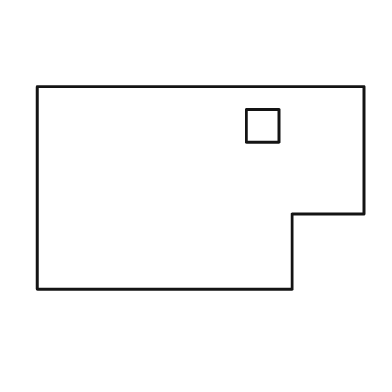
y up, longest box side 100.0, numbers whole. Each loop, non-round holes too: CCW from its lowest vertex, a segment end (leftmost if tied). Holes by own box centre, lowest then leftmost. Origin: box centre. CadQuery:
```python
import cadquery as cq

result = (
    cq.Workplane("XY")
    .moveTo(-50.0, -31.0)
    .lineTo(28.0, -31.0)
    .lineTo(28.0, -8.0)
    .lineTo(50.0, -8.0)
    .lineTo(50.0, 31.0)
    .lineTo(-50.0, 31.0)
    .close()
    .moveTo(14.0, 14.0)
    .lineTo(24.0, 14.0)
    .lineTo(24.0, 24.0)
    .lineTo(14.0, 24.0)
    .close()
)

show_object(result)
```